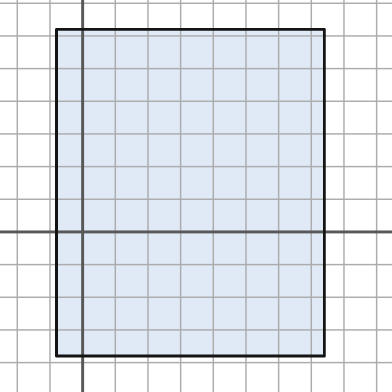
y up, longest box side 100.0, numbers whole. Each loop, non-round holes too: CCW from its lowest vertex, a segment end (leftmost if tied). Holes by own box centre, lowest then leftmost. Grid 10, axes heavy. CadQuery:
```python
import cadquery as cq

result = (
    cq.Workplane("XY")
    .moveTo(-8.0, -38.0)
    .lineTo(74.0, -38.0)
    .lineTo(74.0, 62.0)
    .lineTo(-8.0, 62.0)
    .close()
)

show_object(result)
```